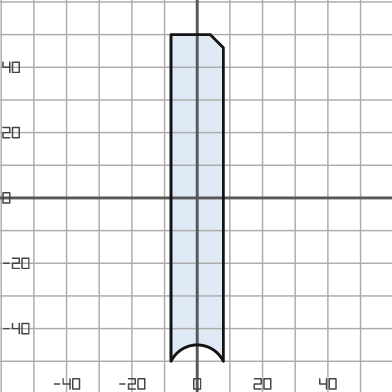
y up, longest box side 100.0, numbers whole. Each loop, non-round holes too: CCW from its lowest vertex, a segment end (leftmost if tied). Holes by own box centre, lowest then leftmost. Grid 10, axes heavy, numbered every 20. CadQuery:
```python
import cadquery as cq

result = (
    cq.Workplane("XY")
    .moveTo(-8.0, -50.0)
    .threePointArc((0.0, -45.0), (8.0, -50.0))
    .lineTo(8.0, 46.0)
    .lineTo(4.0, 50.0)
    .lineTo(-8.0, 50.0)
    .close()
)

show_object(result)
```